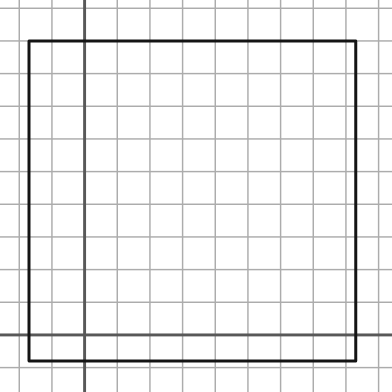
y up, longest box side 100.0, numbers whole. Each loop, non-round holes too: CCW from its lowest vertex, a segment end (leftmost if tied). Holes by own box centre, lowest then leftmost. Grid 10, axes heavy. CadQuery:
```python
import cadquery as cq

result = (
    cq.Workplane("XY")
    .moveTo(-17.0, -8.0)
    .lineTo(83.0, -8.0)
    .lineTo(83.0, 90.0)
    .lineTo(-17.0, 90.0)
    .close()
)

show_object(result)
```